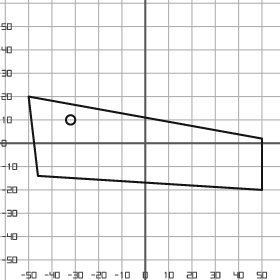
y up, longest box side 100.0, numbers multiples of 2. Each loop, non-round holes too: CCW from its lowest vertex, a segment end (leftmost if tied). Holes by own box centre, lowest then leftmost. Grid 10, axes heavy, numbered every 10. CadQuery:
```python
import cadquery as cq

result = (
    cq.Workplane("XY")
    .moveTo(50.0, -20.0)
    .lineTo(50.0, 2.0)
    .lineTo(-50.0, 20.0)
    .lineTo(-46.0, -14.0)
    .close()
    .moveTo(-32.0, 10.0)
    .circle(2.0)
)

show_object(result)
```